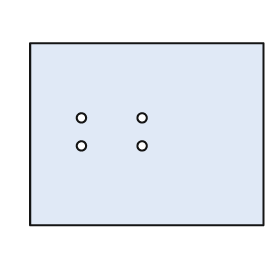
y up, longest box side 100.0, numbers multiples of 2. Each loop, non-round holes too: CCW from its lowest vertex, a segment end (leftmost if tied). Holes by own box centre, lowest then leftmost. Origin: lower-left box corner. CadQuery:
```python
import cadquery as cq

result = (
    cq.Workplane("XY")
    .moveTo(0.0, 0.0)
    .lineTo(100.0, 0.0)
    .lineTo(100.0, 78.0)
    .lineTo(0.0, 78.0)
    .close()
    .moveTo(22.0, 34.0)
    .circle(2.0)
    .moveTo(48.0, 34.0)
    .circle(2.0)
    .moveTo(22.0, 46.0)
    .circle(2.0)
    .moveTo(48.0, 46.0)
    .circle(2.0)
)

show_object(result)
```